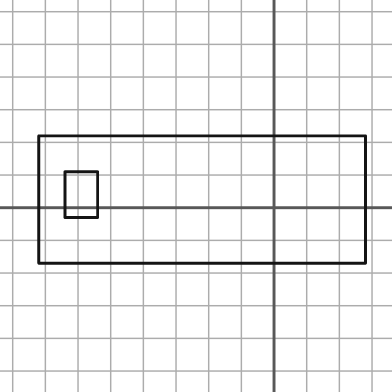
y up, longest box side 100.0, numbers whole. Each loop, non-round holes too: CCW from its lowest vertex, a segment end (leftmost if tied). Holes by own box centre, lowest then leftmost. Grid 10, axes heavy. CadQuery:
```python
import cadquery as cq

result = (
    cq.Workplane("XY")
    .moveTo(-72.0, -17.0)
    .lineTo(28.0, -17.0)
    .lineTo(28.0, 22.0)
    .lineTo(-72.0, 22.0)
    .close()
    .moveTo(-64.0, -3.0)
    .lineTo(-54.0, -3.0)
    .lineTo(-54.0, 11.0)
    .lineTo(-64.0, 11.0)
    .close()
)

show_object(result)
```